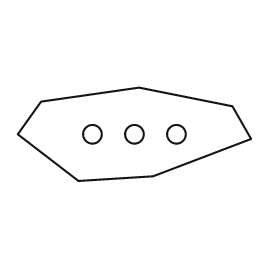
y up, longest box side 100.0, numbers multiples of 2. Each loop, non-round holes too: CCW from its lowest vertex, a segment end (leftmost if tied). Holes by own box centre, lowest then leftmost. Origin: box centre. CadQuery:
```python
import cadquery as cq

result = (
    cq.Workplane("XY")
    .moveTo(-24.0, -20.0)
    .lineTo(8.0, -18.0)
    .lineTo(50.0, -2.0)
    .lineTo(42.0, 12.0)
    .lineTo(2.0, 20.0)
    .lineTo(-40.0, 14.0)
    .lineTo(-50.0, 0.0)
    .close()
    .moveTo(-18.0, 0.0)
    .circle(4.0)
    .moveTo(0.0, 0.0)
    .circle(4.0)
    .moveTo(18.0, 0.0)
    .circle(4.0)
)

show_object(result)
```